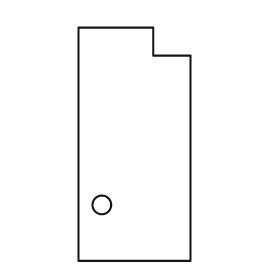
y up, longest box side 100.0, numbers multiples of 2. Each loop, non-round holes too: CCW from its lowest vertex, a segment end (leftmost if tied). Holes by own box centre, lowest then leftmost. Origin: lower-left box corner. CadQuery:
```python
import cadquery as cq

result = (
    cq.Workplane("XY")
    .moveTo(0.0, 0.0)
    .lineTo(48.0, 0.0)
    .lineTo(48.0, 88.0)
    .lineTo(32.0, 88.0)
    .lineTo(32.0, 100.0)
    .lineTo(0.0, 100.0)
    .close()
    .moveTo(10.0, 24.0)
    .circle(4.0)
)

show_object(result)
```